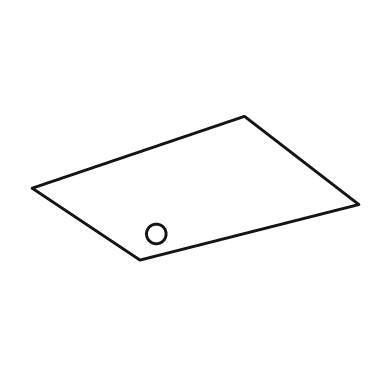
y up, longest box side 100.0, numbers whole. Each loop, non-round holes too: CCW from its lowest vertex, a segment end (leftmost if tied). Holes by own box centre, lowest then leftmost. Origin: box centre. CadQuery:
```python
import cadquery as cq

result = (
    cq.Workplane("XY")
    .moveTo(-17.0, -22.0)
    .lineTo(50.0, -5.0)
    .lineTo(15.0, 22.0)
    .lineTo(-50.0, 0.0)
    .close()
    .moveTo(-12.0, -14.0)
    .circle(3.0)
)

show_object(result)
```